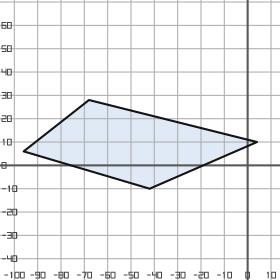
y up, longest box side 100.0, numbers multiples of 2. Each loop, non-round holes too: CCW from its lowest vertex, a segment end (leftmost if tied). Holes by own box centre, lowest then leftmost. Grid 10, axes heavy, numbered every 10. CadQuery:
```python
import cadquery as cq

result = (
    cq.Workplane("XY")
    .moveTo(-42.0, -10.0)
    .lineTo(4.0, 10.0)
    .lineTo(-68.0, 28.0)
    .lineTo(-96.0, 6.0)
    .close()
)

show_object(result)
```